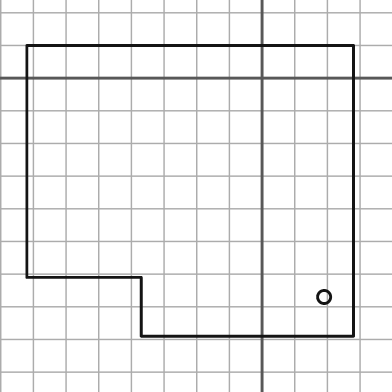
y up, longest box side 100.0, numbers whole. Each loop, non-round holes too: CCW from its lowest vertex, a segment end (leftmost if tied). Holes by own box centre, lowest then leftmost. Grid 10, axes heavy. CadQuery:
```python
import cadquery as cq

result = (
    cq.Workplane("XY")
    .moveTo(-37.0, -79.0)
    .lineTo(28.0, -79.0)
    .lineTo(28.0, 10.0)
    .lineTo(-72.0, 10.0)
    .lineTo(-72.0, -61.0)
    .lineTo(-37.0, -61.0)
    .close()
    .moveTo(19.0, -67.0)
    .circle(2.0)
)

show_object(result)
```